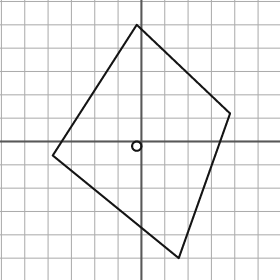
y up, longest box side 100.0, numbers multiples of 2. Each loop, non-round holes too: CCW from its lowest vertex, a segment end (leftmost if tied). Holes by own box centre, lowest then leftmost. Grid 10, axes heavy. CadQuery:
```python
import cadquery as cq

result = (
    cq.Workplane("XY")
    .moveTo(16.0, -50.0)
    .lineTo(38.0, 12.0)
    .lineTo(-2.0, 50.0)
    .lineTo(-38.0, -6.0)
    .close()
    .moveTo(-2.0, -2.0)
    .circle(2.0)
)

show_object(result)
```